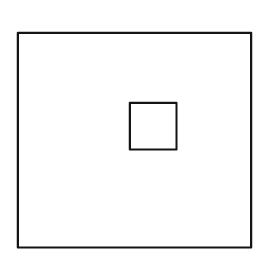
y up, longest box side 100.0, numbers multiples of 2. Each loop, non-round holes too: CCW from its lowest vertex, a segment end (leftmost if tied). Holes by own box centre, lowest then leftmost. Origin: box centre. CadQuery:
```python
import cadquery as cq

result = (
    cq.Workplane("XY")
    .moveTo(-50.0, -46.0)
    .lineTo(50.0, -46.0)
    .lineTo(50.0, 46.0)
    .lineTo(-50.0, 46.0)
    .close()
    .moveTo(-2.0, -4.0)
    .lineTo(18.0, -4.0)
    .lineTo(18.0, 16.0)
    .lineTo(-2.0, 16.0)
    .close()
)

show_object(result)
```